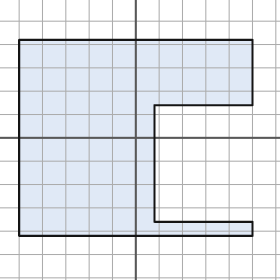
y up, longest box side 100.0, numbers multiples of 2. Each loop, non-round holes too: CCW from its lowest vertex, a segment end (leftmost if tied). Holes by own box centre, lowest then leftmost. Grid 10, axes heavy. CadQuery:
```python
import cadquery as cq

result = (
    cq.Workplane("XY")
    .moveTo(-50.0, -42.0)
    .lineTo(50.0, -42.0)
    .lineTo(50.0, -36.0)
    .lineTo(8.0, -36.0)
    .lineTo(8.0, 14.0)
    .lineTo(50.0, 14.0)
    .lineTo(50.0, 42.0)
    .lineTo(-50.0, 42.0)
    .close()
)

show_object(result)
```